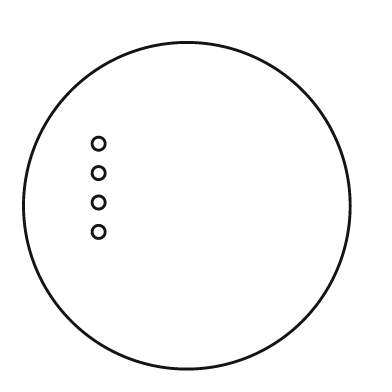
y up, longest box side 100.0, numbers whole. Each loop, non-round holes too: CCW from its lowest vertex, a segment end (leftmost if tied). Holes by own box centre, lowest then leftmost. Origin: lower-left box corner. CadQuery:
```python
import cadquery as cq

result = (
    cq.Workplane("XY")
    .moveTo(50.0, 50.0)
    .circle(50.0)
    .moveTo(23.0, 42.0)
    .circle(2.0)
    .moveTo(23.0, 51.0)
    .circle(2.0)
    .moveTo(23.0, 60.0)
    .circle(2.0)
    .moveTo(23.0, 69.0)
    .circle(2.0)
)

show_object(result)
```